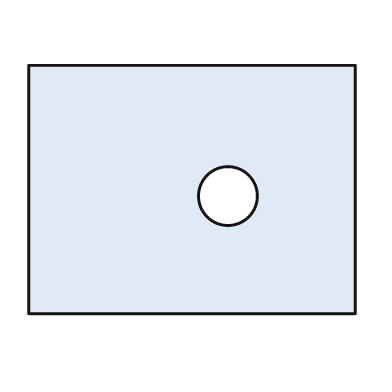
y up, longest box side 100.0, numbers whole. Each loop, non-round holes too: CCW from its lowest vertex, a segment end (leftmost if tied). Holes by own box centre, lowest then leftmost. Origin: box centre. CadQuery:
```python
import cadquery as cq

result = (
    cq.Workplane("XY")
    .moveTo(-50.0, -38.0)
    .lineTo(50.0, -38.0)
    .lineTo(50.0, 38.0)
    .lineTo(-50.0, 38.0)
    .close()
    .moveTo(11.0, -2.0)
    .circle(9.0)
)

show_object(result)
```